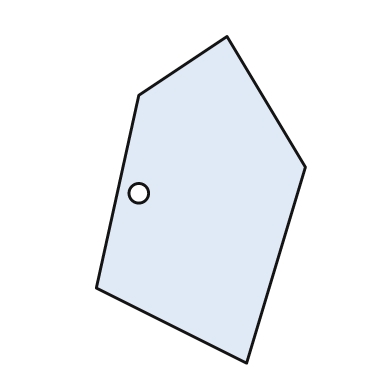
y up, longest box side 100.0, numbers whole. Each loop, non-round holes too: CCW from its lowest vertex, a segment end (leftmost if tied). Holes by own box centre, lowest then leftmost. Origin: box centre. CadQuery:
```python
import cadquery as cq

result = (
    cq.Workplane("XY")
    .moveTo(14.0, -50.0)
    .lineTo(32.0, 10.0)
    .lineTo(8.0, 50.0)
    .lineTo(-19.0, 32.0)
    .lineTo(-32.0, -27.0)
    .close()
    .moveTo(-19.0, 2.0)
    .circle(3.0)
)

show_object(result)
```